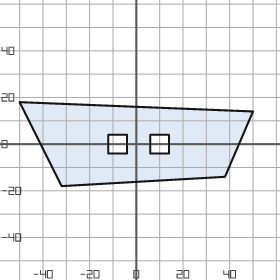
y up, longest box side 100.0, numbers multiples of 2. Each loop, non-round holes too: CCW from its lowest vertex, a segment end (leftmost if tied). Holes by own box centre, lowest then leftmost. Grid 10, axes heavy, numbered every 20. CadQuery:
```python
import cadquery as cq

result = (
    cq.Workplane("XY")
    .moveTo(-32.0, -18.0)
    .lineTo(38.0, -14.0)
    .lineTo(50.0, 14.0)
    .lineTo(-50.0, 18.0)
    .close()
    .moveTo(-12.0, -4.0)
    .lineTo(-4.0, -4.0)
    .lineTo(-4.0, 4.0)
    .lineTo(-12.0, 4.0)
    .close()
    .moveTo(6.0, -4.0)
    .lineTo(14.0, -4.0)
    .lineTo(14.0, 4.0)
    .lineTo(6.0, 4.0)
    .close()
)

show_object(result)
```